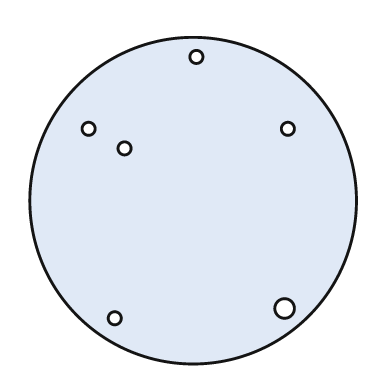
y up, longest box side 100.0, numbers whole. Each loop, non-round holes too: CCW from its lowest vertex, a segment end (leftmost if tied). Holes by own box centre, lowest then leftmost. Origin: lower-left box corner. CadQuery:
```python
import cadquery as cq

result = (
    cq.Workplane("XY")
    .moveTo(50.0, 50.0)
    .circle(50.0)
    .moveTo(26.0, 14.0)
    .circle(2.0)
    .moveTo(78.0, 17.0)
    .circle(3.0)
    .moveTo(29.0, 66.0)
    .circle(2.0)
    .moveTo(18.0, 72.0)
    .circle(2.0)
    .moveTo(79.0, 72.0)
    .circle(2.0)
    .moveTo(51.0, 94.0)
    .circle(2.0)
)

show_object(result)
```